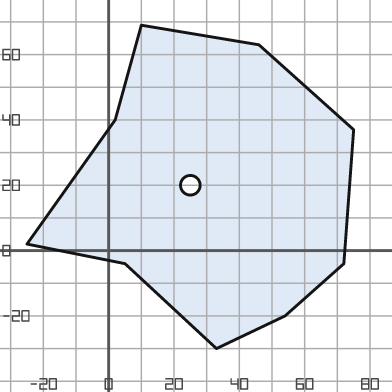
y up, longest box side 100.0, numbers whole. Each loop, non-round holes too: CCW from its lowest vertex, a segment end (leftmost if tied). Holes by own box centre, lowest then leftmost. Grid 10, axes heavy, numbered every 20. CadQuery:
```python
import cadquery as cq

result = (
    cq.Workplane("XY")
    .moveTo(33.0, -30.0)
    .lineTo(54.0, -20.0)
    .lineTo(72.0, -4.0)
    .lineTo(75.0, 37.0)
    .lineTo(46.0, 63.0)
    .lineTo(10.0, 69.0)
    .lineTo(2.0, 40.0)
    .lineTo(-25.0, 2.0)
    .lineTo(5.0, -4.0)
    .close()
    .moveTo(25.0, 20.0)
    .circle(3.0)
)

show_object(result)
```